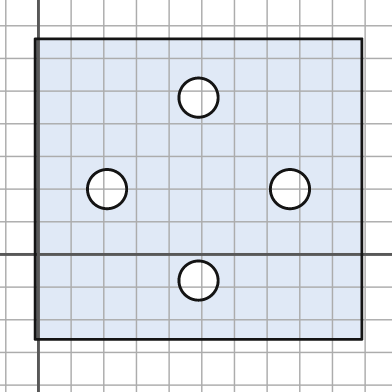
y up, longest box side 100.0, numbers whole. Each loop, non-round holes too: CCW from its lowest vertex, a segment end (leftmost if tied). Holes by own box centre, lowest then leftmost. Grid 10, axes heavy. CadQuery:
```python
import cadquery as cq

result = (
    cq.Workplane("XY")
    .moveTo(-1.0, -26.0)
    .lineTo(99.0, -26.0)
    .lineTo(99.0, 66.0)
    .lineTo(-1.0, 66.0)
    .close()
    .moveTo(49.0, -8.0)
    .circle(6.0)
    .moveTo(21.0, 20.0)
    .circle(6.0)
    .moveTo(77.0, 20.0)
    .circle(6.0)
    .moveTo(49.0, 48.0)
    .circle(6.0)
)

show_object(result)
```